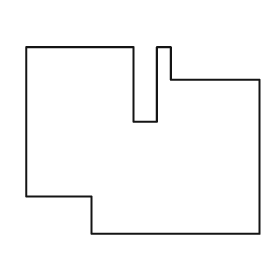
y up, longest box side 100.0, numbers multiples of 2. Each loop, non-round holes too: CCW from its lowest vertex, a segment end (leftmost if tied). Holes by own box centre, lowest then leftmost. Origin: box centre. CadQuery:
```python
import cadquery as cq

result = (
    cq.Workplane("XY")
    .moveTo(-22.0, -40.0)
    .lineTo(50.0, -40.0)
    .lineTo(50.0, 26.0)
    .lineTo(12.0, 26.0)
    .lineTo(12.0, 40.0)
    .lineTo(6.0, 40.0)
    .lineTo(6.0, 8.0)
    .lineTo(-4.0, 8.0)
    .lineTo(-4.0, 40.0)
    .lineTo(-50.0, 40.0)
    .lineTo(-50.0, -24.0)
    .lineTo(-22.0, -24.0)
    .close()
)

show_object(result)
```